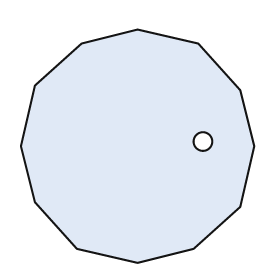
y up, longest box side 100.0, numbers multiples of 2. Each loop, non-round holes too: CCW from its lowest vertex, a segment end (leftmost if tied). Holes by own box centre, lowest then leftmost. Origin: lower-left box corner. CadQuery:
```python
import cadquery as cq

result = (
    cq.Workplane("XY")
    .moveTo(50.0, 0.0)
    .lineTo(74.0, 6.0)
    .lineTo(94.0, 24.0)
    .lineTo(100.0, 50.0)
    .lineTo(94.0, 74.0)
    .lineTo(76.0, 94.0)
    .lineTo(50.0, 100.0)
    .lineTo(26.0, 94.0)
    .lineTo(6.0, 76.0)
    .lineTo(0.0, 50.0)
    .lineTo(6.0, 26.0)
    .lineTo(24.0, 6.0)
    .close()
    .moveTo(78.0, 52.0)
    .circle(4.0)
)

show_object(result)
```